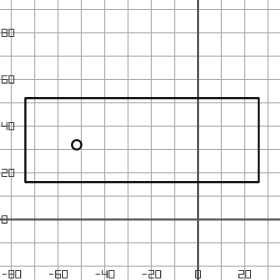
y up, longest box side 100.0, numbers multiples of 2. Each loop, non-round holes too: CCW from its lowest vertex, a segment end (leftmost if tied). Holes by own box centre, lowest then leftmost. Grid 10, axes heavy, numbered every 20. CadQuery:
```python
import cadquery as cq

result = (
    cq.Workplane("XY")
    .moveTo(-74.0, 16.0)
    .lineTo(26.0, 16.0)
    .lineTo(26.0, 52.0)
    .lineTo(-74.0, 52.0)
    .close()
    .moveTo(-52.0, 32.0)
    .circle(2.0)
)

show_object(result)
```